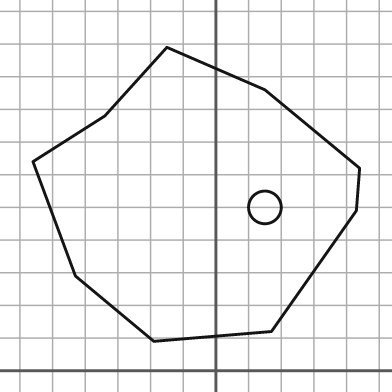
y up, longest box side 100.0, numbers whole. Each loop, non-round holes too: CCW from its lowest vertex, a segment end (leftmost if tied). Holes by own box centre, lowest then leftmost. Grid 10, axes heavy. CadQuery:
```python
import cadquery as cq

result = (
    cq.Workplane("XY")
    .moveTo(-19.0, 9.0)
    .lineTo(17.0, 12.0)
    .lineTo(43.0, 49.0)
    .lineTo(44.0, 62.0)
    .lineTo(15.0, 86.0)
    .lineTo(-15.0, 99.0)
    .lineTo(-34.0, 78.0)
    .lineTo(-56.0, 64.0)
    .lineTo(-43.0, 29.0)
    .close()
    .moveTo(15.0, 50.0)
    .circle(5.0)
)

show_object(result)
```